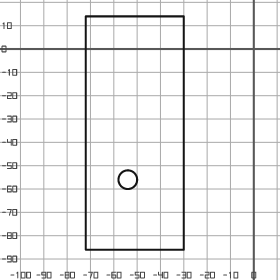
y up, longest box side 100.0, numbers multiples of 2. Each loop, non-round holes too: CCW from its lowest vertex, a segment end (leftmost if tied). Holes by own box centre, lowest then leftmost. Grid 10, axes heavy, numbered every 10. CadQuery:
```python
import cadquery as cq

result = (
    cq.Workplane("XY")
    .moveTo(-72.0, -86.0)
    .lineTo(-30.0, -86.0)
    .lineTo(-30.0, 14.0)
    .lineTo(-72.0, 14.0)
    .close()
    .moveTo(-54.0, -56.0)
    .circle(4.0)
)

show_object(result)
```